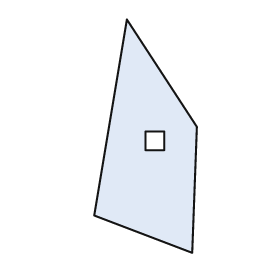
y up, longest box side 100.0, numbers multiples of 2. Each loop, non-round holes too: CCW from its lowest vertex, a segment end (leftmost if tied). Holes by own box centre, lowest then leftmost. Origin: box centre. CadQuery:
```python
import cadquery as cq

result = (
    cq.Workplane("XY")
    .moveTo(20.0, -50.0)
    .lineTo(22.0, 4.0)
    .lineTo(-8.0, 50.0)
    .lineTo(-22.0, -34.0)
    .close()
    .moveTo(0.0, -6.0)
    .lineTo(8.0, -6.0)
    .lineTo(8.0, 2.0)
    .lineTo(0.0, 2.0)
    .close()
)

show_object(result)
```